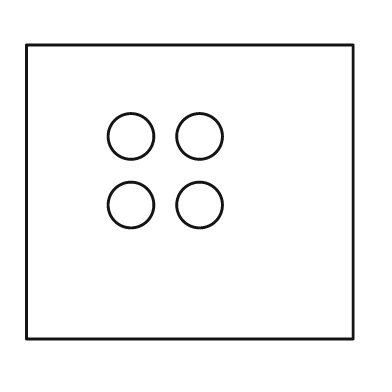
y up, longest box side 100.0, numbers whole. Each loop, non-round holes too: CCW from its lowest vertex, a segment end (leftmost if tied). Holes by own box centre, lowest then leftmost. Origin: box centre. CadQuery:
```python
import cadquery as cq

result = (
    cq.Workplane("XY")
    .moveTo(-50.0, -45.0)
    .lineTo(50.0, -45.0)
    .lineTo(50.0, 45.0)
    .lineTo(-50.0, 45.0)
    .close()
    .moveTo(-18.0, -4.0)
    .circle(7.0)
    .moveTo(3.0, -4.0)
    .circle(7.0)
    .moveTo(-18.0, 17.0)
    .circle(7.0)
    .moveTo(3.0, 17.0)
    .circle(7.0)
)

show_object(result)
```